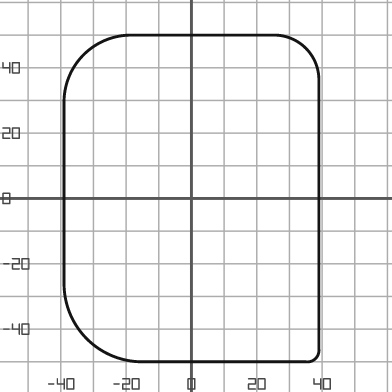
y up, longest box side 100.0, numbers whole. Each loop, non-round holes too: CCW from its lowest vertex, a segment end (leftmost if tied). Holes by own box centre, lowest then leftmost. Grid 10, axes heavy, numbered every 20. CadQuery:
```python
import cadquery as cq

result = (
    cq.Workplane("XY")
    .moveTo(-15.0, -50.0)
    .lineTo(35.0, -50.0)
    .threePointArc((38.0, -49.0), (39.0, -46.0))
    .lineTo(39.0, 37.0)
    .threePointArc((35.0, 46.0), (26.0, 50.0))
    .lineTo(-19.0, 50.0)
    .threePointArc((-33.0, 44.0), (-39.0, 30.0))
    .lineTo(-39.0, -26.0)
    .threePointArc((-32.0, -43.0), (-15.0, -50.0))
    .close()
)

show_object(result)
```